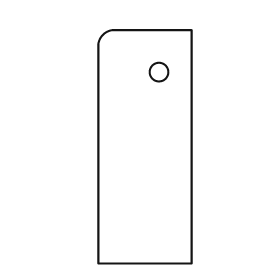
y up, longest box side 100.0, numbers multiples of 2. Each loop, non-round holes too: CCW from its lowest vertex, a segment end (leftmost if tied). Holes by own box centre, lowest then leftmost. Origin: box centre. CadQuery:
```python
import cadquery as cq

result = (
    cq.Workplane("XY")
    .moveTo(-20.0, -50.0)
    .lineTo(20.0, -50.0)
    .lineTo(20.0, 50.0)
    .lineTo(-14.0, 50.0)
    .threePointArc((-18.0, 48.0), (-20.0, 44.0))
    .close()
    .moveTo(6.0, 32.0)
    .circle(4.0)
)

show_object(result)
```